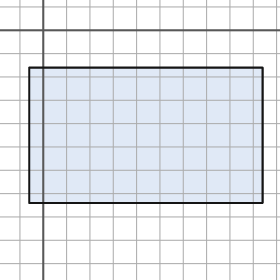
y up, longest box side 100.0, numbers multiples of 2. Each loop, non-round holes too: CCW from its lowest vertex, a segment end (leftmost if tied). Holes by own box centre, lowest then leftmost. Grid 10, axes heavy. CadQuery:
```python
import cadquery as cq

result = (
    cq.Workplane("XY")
    .moveTo(-6.0, -74.0)
    .lineTo(94.0, -74.0)
    .lineTo(94.0, -16.0)
    .lineTo(-6.0, -16.0)
    .close()
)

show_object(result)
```